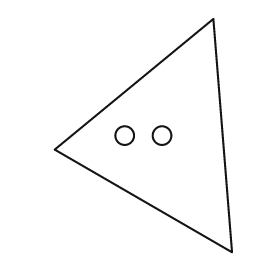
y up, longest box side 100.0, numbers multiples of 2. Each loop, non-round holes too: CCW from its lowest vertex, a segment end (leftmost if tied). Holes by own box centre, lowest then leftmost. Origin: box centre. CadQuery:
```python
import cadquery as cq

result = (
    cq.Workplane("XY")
    .moveTo(38.0, -50.0)
    .lineTo(30.0, 50.0)
    .lineTo(-38.0, -6.0)
    .close()
    .moveTo(-8.0, 0.0)
    .circle(4.0)
    .moveTo(8.0, 0.0)
    .circle(4.0)
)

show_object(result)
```